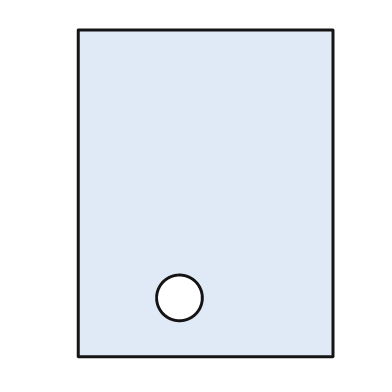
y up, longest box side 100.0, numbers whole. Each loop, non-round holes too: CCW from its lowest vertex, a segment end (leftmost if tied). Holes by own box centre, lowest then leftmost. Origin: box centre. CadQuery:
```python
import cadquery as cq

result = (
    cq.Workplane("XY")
    .moveTo(-39.0, -50.0)
    .lineTo(39.0, -50.0)
    .lineTo(39.0, 50.0)
    .lineTo(-39.0, 50.0)
    .close()
    .moveTo(-8.0, -32.0)
    .circle(7.0)
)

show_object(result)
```